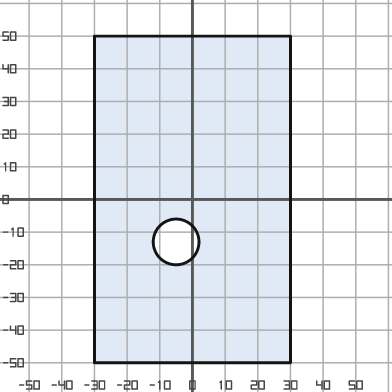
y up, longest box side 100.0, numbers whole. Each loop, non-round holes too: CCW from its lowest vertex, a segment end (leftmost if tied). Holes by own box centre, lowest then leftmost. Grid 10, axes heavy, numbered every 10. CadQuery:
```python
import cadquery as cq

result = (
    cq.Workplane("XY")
    .moveTo(-30.0, -50.0)
    .lineTo(30.0, -50.0)
    .lineTo(30.0, 50.0)
    .lineTo(-30.0, 50.0)
    .close()
    .moveTo(-5.0, -13.0)
    .circle(7.0)
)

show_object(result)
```